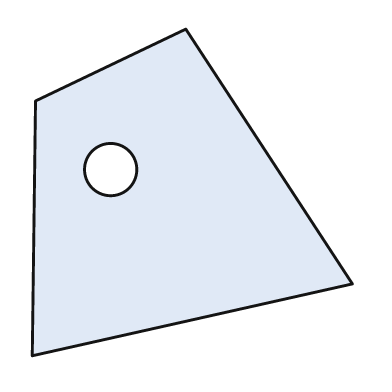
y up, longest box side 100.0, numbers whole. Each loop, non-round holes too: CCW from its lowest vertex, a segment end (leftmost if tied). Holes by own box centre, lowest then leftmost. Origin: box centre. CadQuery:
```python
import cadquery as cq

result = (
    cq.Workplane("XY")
    .moveTo(-49.0, -50.0)
    .lineTo(49.0, -28.0)
    .lineTo(-2.0, 50.0)
    .lineTo(-48.0, 28.0)
    .close()
    .moveTo(-25.0, 7.0)
    .circle(8.0)
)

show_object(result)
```